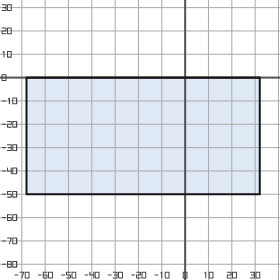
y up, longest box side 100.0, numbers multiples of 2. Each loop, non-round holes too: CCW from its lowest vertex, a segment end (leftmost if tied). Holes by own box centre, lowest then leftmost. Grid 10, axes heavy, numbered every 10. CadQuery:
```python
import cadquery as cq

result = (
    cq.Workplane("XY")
    .moveTo(-68.0, -50.0)
    .lineTo(32.0, -50.0)
    .lineTo(32.0, 0.0)
    .lineTo(-68.0, 0.0)
    .close()
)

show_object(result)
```